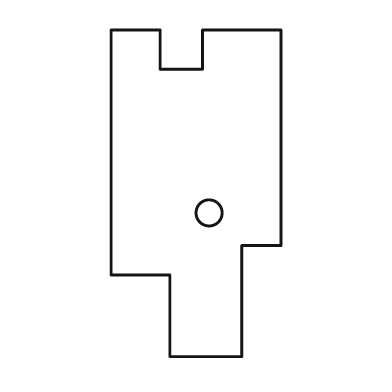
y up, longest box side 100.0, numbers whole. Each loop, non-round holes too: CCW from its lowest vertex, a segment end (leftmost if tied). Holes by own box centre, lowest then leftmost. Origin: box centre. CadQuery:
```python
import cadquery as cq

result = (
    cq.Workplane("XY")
    .moveTo(-8.0, -50.0)
    .lineTo(14.0, -50.0)
    .lineTo(14.0, -16.0)
    .lineTo(26.0, -16.0)
    .lineTo(26.0, 50.0)
    .lineTo(2.0, 50.0)
    .lineTo(2.0, 38.0)
    .lineTo(-11.0, 38.0)
    .lineTo(-11.0, 50.0)
    .lineTo(-26.0, 50.0)
    .lineTo(-26.0, -25.0)
    .lineTo(-8.0, -25.0)
    .close()
    .moveTo(4.0, -6.0)
    .circle(4.0)
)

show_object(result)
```